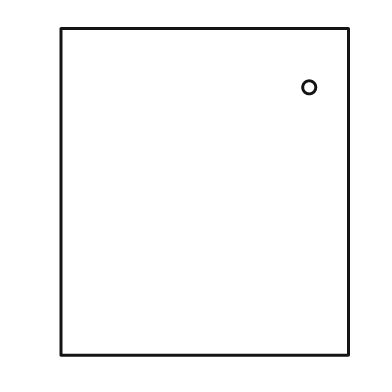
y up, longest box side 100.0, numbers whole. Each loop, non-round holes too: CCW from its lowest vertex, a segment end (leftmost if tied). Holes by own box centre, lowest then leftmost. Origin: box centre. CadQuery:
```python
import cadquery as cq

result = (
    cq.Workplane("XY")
    .moveTo(-44.0, -50.0)
    .lineTo(44.0, -50.0)
    .lineTo(44.0, 50.0)
    .lineTo(-44.0, 50.0)
    .close()
    .moveTo(32.0, 32.0)
    .circle(2.0)
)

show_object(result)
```